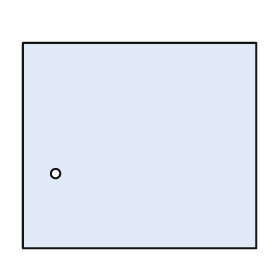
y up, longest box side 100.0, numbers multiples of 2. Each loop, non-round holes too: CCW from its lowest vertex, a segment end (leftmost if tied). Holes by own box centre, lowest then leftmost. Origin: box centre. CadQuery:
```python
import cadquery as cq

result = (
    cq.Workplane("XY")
    .moveTo(-50.0, -44.0)
    .lineTo(50.0, -44.0)
    .lineTo(50.0, 44.0)
    .lineTo(-50.0, 44.0)
    .close()
    .moveTo(-36.0, -12.0)
    .circle(2.0)
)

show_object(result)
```